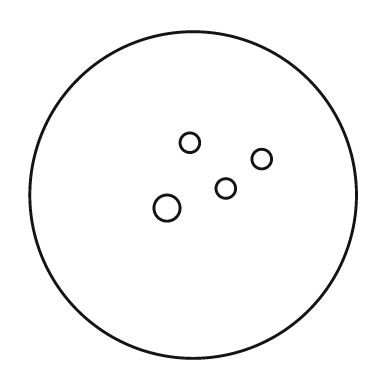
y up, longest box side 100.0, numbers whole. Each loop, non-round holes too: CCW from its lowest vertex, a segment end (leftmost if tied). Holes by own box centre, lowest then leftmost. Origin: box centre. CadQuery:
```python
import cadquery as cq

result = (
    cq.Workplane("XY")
    .moveTo(0.0, 0.0)
    .circle(50.0)
    .moveTo(-8.0, -4.0)
    .circle(4.0)
    .moveTo(10.0, 2.0)
    .circle(3.0)
    .moveTo(21.0, 11.0)
    .circle(3.0)
    .moveTo(-1.0, 16.0)
    .circle(3.0)
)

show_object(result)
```